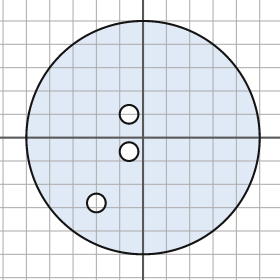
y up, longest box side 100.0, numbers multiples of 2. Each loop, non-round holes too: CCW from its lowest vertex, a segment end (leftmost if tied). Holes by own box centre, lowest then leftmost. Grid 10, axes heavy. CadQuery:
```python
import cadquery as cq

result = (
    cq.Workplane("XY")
    .moveTo(0.0, 0.0)
    .circle(50.0)
    .moveTo(-20.0, -28.0)
    .circle(4.0)
    .moveTo(-6.0, -6.0)
    .circle(4.0)
    .moveTo(-6.0, 10.0)
    .circle(4.0)
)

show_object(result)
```